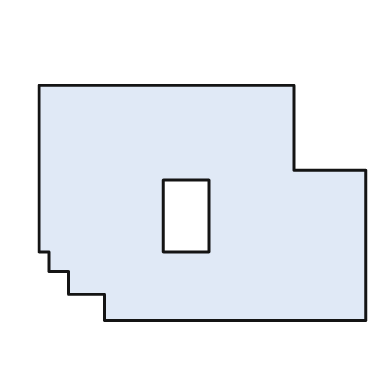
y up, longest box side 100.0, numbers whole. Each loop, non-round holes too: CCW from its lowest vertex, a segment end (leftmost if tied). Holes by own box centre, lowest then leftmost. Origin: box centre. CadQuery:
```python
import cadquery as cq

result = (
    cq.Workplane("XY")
    .moveTo(-30.0, -36.0)
    .lineTo(50.0, -36.0)
    .lineTo(50.0, 10.0)
    .lineTo(28.0, 10.0)
    .lineTo(28.0, 36.0)
    .lineTo(-50.0, 36.0)
    .lineTo(-50.0, -15.0)
    .lineTo(-47.0, -15.0)
    .lineTo(-47.0, -21.0)
    .lineTo(-41.0, -21.0)
    .lineTo(-41.0, -28.0)
    .lineTo(-30.0, -28.0)
    .close()
    .moveTo(-12.0, -15.0)
    .lineTo(2.0, -15.0)
    .lineTo(2.0, 7.0)
    .lineTo(-12.0, 7.0)
    .close()
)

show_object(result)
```